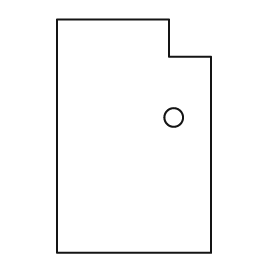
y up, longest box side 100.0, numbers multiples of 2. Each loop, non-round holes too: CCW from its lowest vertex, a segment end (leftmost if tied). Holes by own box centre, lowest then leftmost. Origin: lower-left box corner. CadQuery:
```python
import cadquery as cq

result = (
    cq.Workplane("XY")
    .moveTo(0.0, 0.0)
    .lineTo(66.0, 0.0)
    .lineTo(66.0, 84.0)
    .lineTo(48.0, 84.0)
    .lineTo(48.0, 100.0)
    .lineTo(0.0, 100.0)
    .close()
    .moveTo(50.0, 58.0)
    .circle(4.0)
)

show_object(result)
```